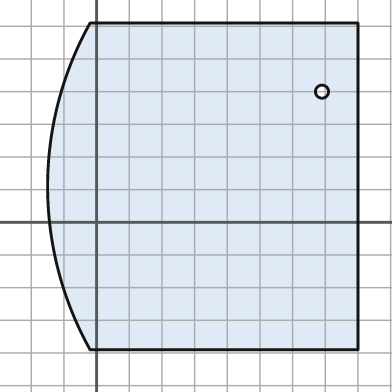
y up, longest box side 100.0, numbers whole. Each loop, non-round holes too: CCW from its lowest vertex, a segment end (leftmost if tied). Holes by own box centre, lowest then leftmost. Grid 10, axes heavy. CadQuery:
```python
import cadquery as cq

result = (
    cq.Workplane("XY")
    .moveTo(-2.0, -39.0)
    .lineTo(80.0, -39.0)
    .lineTo(80.0, 61.0)
    .lineTo(-2.0, 61.0)
    .threePointArc((-15.0, 11.0), (-2.0, -39.0))
    .close()
    .moveTo(69.0, 40.0)
    .circle(2.0)
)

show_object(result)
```